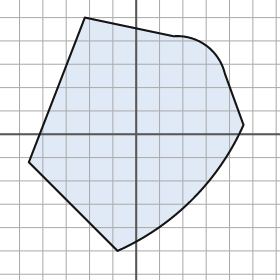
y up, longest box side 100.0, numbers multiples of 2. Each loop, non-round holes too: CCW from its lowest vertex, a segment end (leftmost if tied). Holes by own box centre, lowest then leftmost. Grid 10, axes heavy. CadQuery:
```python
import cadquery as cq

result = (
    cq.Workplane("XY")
    .moveTo(-8.0, -50.0)
    .threePointArc((24.0, -28.0), (46.0, 4.0))
    .lineTo(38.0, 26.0)
    .threePointArc((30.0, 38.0), (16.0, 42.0))
    .lineTo(-22.0, 50.0)
    .lineTo(-46.0, -12.0)
    .close()
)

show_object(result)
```